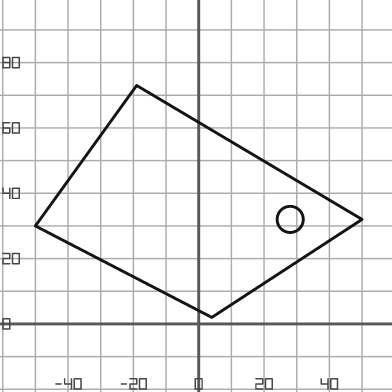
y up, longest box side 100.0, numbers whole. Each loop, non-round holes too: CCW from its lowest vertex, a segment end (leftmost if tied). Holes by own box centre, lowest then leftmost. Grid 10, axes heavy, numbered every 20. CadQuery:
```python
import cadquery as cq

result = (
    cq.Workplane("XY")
    .moveTo(4.0, 2.0)
    .lineTo(50.0, 32.0)
    .lineTo(-19.0, 73.0)
    .lineTo(-50.0, 30.0)
    .close()
    .moveTo(28.0, 32.0)
    .circle(4.0)
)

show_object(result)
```